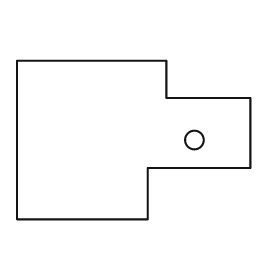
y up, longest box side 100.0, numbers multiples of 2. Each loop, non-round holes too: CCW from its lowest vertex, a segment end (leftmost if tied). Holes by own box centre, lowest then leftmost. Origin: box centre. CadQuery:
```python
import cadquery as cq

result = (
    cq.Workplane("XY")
    .moveTo(-50.0, -34.0)
    .lineTo(6.0, -34.0)
    .lineTo(6.0, -12.0)
    .lineTo(50.0, -12.0)
    .lineTo(50.0, 18.0)
    .lineTo(14.0, 18.0)
    .lineTo(14.0, 34.0)
    .lineTo(-50.0, 34.0)
    .close()
    .moveTo(26.0, 0.0)
    .circle(4.0)
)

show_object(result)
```